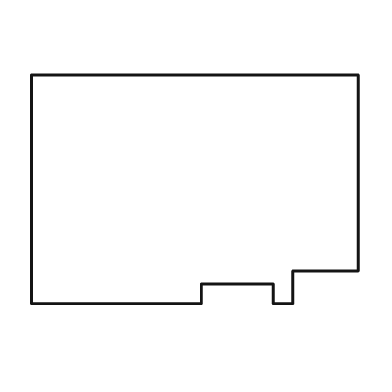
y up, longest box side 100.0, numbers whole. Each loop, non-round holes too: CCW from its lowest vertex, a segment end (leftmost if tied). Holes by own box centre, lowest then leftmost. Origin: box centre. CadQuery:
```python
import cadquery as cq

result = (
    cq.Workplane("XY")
    .moveTo(-50.0, -35.0)
    .lineTo(2.0, -35.0)
    .lineTo(2.0, -29.0)
    .lineTo(24.0, -29.0)
    .lineTo(24.0, -35.0)
    .lineTo(30.0, -35.0)
    .lineTo(30.0, -25.0)
    .lineTo(50.0, -25.0)
    .lineTo(50.0, 35.0)
    .lineTo(-50.0, 35.0)
    .close()
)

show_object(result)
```